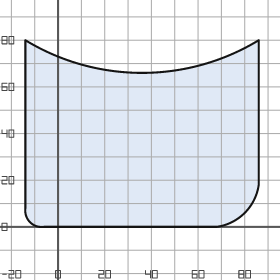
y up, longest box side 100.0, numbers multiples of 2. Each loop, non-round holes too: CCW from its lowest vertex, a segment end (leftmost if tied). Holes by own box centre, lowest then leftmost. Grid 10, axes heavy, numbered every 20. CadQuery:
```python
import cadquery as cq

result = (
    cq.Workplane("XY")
    .moveTo(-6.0, 0.0)
    .lineTo(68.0, 0.0)
    .threePointArc((80.0, 6.0), (86.0, 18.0))
    .lineTo(86.0, 80.0)
    .threePointArc((36.0, 66.0), (-14.0, 80.0))
    .lineTo(-14.0, 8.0)
    .threePointArc((-12.0, 2.0), (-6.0, 0.0))
    .close()
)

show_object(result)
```